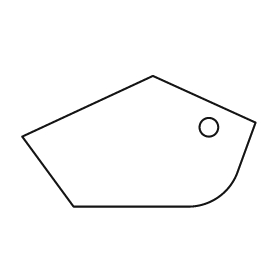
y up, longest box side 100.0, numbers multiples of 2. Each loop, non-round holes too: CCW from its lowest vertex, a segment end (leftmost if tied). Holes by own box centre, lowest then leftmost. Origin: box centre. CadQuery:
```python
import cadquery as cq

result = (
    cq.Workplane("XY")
    .moveTo(-28.0, -28.0)
    .lineTo(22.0, -28.0)
    .threePointArc((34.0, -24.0), (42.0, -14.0))
    .lineTo(50.0, 8.0)
    .lineTo(6.0, 28.0)
    .lineTo(-50.0, 2.0)
    .close()
    .moveTo(30.0, 6.0)
    .circle(4.0)
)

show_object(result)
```